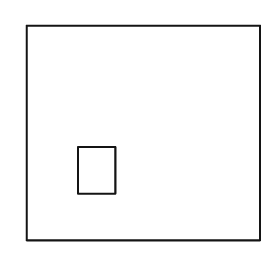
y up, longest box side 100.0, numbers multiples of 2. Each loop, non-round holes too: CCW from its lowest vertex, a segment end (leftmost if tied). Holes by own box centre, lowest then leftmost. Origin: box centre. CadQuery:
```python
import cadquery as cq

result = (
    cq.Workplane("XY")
    .moveTo(-50.0, -46.0)
    .lineTo(50.0, -46.0)
    .lineTo(50.0, 46.0)
    .lineTo(-50.0, 46.0)
    .close()
    .moveTo(-28.0, -26.0)
    .lineTo(-12.0, -26.0)
    .lineTo(-12.0, -6.0)
    .lineTo(-28.0, -6.0)
    .close()
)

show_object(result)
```